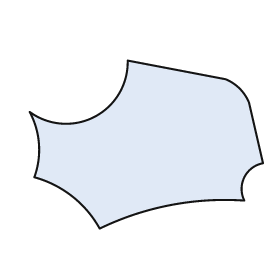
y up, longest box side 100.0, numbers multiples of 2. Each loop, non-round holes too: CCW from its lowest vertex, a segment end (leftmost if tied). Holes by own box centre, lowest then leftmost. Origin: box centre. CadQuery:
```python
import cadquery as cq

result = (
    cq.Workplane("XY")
    .moveTo(-20.0, -36.0)
    .threePointArc((10.0, -26.0), (42.0, -24.0))
    .threePointArc((42.0, -14.0), (50.0, -8.0))
    .lineTo(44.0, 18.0)
    .threePointArc((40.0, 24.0), (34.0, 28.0))
    .lineTo(-8.0, 36.0)
    .threePointArc((-22.0, 12.0), (-50.0, 14.0))
    .threePointArc((-46.0, 0.0), (-48.0, -14.0))
    .threePointArc((-32.0, -22.0), (-20.0, -36.0))
    .close()
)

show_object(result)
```